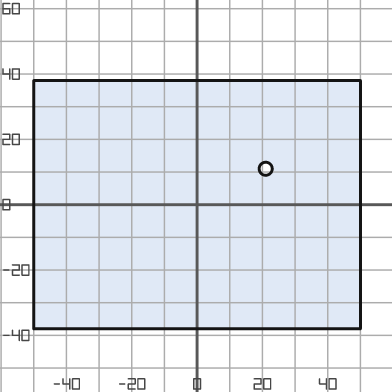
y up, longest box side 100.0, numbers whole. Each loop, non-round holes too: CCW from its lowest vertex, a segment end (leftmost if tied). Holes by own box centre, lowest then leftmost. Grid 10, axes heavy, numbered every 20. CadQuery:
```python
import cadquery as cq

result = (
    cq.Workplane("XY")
    .moveTo(-50.0, -38.0)
    .lineTo(50.0, -38.0)
    .lineTo(50.0, 38.0)
    .lineTo(-50.0, 38.0)
    .close()
    .moveTo(21.0, 11.0)
    .circle(2.0)
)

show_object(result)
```